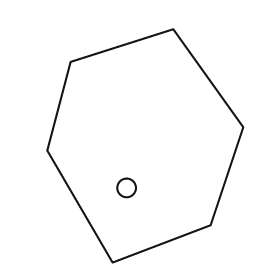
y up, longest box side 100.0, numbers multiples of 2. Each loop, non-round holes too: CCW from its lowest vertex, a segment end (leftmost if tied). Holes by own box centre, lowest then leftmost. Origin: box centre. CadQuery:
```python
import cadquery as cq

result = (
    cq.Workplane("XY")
    .moveTo(-14.0, -50.0)
    .lineTo(28.0, -34.0)
    .lineTo(42.0, 8.0)
    .lineTo(12.0, 50.0)
    .lineTo(-32.0, 36.0)
    .lineTo(-42.0, -2.0)
    .close()
    .moveTo(-8.0, -18.0)
    .circle(4.0)
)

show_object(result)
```